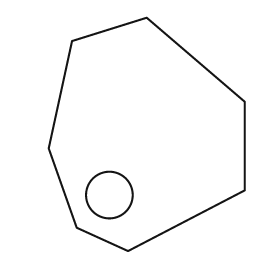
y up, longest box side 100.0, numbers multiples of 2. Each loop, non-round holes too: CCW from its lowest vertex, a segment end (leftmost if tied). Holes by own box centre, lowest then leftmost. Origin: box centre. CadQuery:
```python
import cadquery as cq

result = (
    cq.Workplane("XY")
    .moveTo(-8.0, -50.0)
    .lineTo(42.0, -24.0)
    .lineTo(42.0, 14.0)
    .lineTo(0.0, 50.0)
    .lineTo(-32.0, 40.0)
    .lineTo(-42.0, -6.0)
    .lineTo(-30.0, -40.0)
    .close()
    .moveTo(-16.0, -26.0)
    .circle(10.0)
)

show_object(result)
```